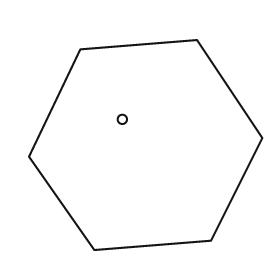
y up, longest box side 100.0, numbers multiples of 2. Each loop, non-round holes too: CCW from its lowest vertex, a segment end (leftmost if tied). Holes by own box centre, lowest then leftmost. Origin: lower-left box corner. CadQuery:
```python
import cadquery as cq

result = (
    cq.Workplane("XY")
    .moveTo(28.0, 0.0)
    .lineTo(78.0, 4.0)
    .lineTo(100.0, 48.0)
    .lineTo(72.0, 90.0)
    .lineTo(22.0, 86.0)
    .lineTo(0.0, 40.0)
    .close()
    .moveTo(40.0, 56.0)
    .circle(2.0)
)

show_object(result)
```